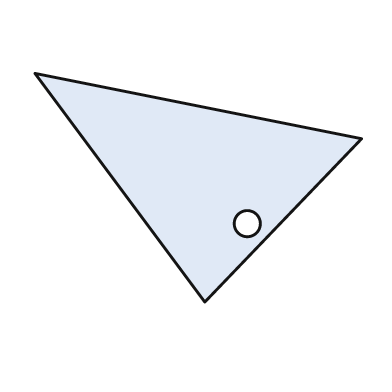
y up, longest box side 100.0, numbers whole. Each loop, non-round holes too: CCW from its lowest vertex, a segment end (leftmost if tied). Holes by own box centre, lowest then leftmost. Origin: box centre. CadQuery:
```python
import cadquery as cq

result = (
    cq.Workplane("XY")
    .moveTo(2.0, -35.0)
    .lineTo(50.0, 15.0)
    .lineTo(-50.0, 35.0)
    .close()
    .moveTo(15.0, -11.0)
    .circle(4.0)
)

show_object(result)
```